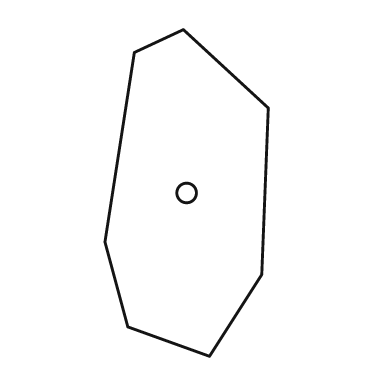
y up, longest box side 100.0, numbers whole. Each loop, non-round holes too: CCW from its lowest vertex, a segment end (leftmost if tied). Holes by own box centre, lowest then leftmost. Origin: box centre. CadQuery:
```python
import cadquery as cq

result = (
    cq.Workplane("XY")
    .moveTo(7.0, -50.0)
    .lineTo(23.0, -25.0)
    .lineTo(25.0, 26.0)
    .lineTo(-1.0, 50.0)
    .lineTo(-16.0, 43.0)
    .lineTo(-25.0, -15.0)
    .lineTo(-18.0, -41.0)
    .close()
    .moveTo(0.0, 0.0)
    .circle(3.0)
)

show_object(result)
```